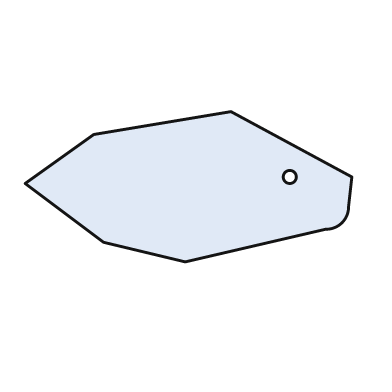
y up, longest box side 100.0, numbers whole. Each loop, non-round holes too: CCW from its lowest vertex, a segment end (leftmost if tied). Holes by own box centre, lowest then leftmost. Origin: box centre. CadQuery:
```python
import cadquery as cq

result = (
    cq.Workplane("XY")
    .moveTo(-1.0, -23.0)
    .lineTo(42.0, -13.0)
    .threePointArc((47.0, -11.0), (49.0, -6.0))
    .lineTo(50.0, 3.0)
    .lineTo(13.0, 23.0)
    .lineTo(-29.0, 16.0)
    .lineTo(-50.0, 1.0)
    .lineTo(-26.0, -17.0)
    .close()
    .moveTo(31.0, 3.0)
    .circle(2.0)
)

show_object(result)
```